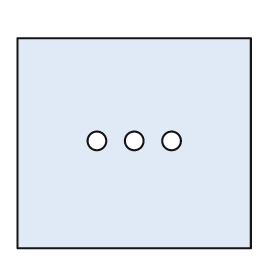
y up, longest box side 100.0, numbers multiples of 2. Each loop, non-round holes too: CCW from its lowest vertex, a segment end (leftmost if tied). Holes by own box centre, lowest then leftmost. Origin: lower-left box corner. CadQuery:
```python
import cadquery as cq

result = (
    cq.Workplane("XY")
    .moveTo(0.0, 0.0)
    .lineTo(100.0, 0.0)
    .lineTo(100.0, 90.0)
    .lineTo(0.0, 90.0)
    .close()
    .moveTo(34.0, 46.0)
    .circle(4.0)
    .moveTo(50.0, 46.0)
    .circle(4.0)
    .moveTo(66.0, 46.0)
    .circle(4.0)
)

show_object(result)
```